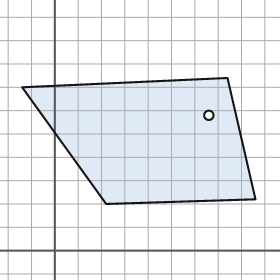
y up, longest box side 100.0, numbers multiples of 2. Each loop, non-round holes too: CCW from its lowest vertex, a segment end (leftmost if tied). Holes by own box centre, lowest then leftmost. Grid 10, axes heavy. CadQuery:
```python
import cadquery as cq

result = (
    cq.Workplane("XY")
    .moveTo(22.0, 20.0)
    .lineTo(86.0, 22.0)
    .lineTo(74.0, 74.0)
    .lineTo(-14.0, 70.0)
    .close()
    .moveTo(66.0, 58.0)
    .circle(2.0)
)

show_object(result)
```